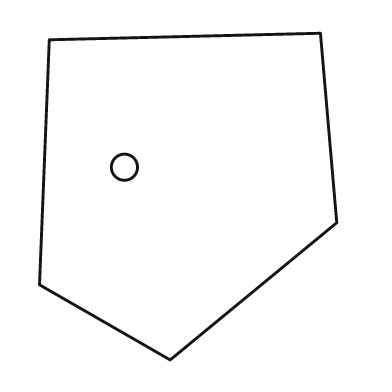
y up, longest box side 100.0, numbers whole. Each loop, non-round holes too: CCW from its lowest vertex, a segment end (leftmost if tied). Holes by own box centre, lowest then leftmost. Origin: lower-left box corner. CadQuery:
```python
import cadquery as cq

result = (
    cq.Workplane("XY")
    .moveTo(40.0, 0.0)
    .lineTo(91.0, 42.0)
    .lineTo(86.0, 100.0)
    .lineTo(3.0, 98.0)
    .lineTo(0.0, 23.0)
    .close()
    .moveTo(26.0, 59.0)
    .circle(4.0)
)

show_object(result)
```